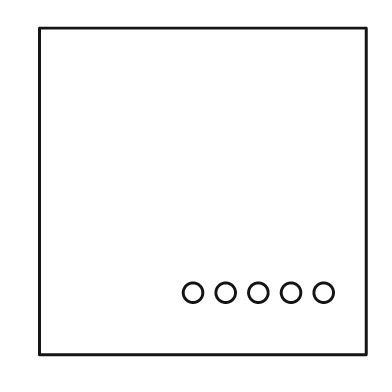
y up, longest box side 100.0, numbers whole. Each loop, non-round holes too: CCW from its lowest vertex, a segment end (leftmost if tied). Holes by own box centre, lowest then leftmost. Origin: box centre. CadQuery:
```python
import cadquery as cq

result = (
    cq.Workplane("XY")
    .moveTo(-50.0, -50.0)
    .lineTo(50.0, -50.0)
    .lineTo(50.0, 50.0)
    .lineTo(-50.0, 50.0)
    .close()
    .moveTo(-3.0, -31.0)
    .circle(3.0)
    .moveTo(7.0, -31.0)
    .circle(3.0)
    .moveTo(17.0, -31.0)
    .circle(3.0)
    .moveTo(27.0, -31.0)
    .circle(3.0)
    .moveTo(37.0, -31.0)
    .circle(3.0)
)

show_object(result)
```